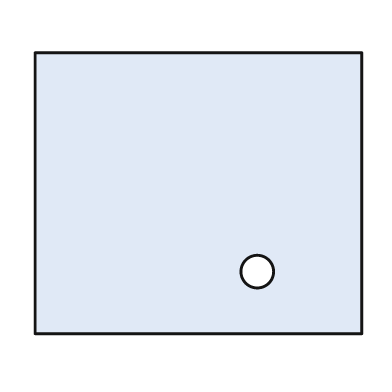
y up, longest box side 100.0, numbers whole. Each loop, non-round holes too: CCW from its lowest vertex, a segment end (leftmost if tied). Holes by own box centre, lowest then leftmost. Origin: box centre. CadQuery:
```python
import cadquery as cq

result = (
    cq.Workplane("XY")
    .moveTo(-50.0, -43.0)
    .lineTo(50.0, -43.0)
    .lineTo(50.0, 43.0)
    .lineTo(-50.0, 43.0)
    .close()
    .moveTo(18.0, -24.0)
    .circle(5.0)
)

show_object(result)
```